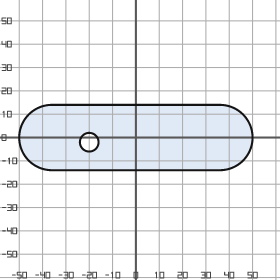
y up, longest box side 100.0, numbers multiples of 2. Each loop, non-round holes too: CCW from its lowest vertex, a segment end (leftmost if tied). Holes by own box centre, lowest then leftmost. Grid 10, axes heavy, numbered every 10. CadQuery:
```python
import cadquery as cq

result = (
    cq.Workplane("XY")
    .moveTo(-36.0, -14.0)
    .lineTo(36.0, -14.0)
    .threePointArc((50.0, 0.0), (36.0, 14.0))
    .lineTo(-36.0, 14.0)
    .threePointArc((-50.0, 0.0), (-36.0, -14.0))
    .close()
    .moveTo(-20.0, -2.0)
    .circle(4.0)
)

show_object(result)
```